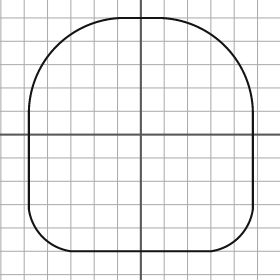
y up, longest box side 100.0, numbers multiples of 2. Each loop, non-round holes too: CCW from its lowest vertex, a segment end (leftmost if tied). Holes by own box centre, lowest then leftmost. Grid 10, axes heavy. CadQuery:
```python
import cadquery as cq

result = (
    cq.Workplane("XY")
    .moveTo(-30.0, -50.0)
    .lineTo(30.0, -50.0)
    .threePointArc((42.0, -44.0), (48.0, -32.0))
    .lineTo(48.0, 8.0)
    .threePointArc((36.0, 38.0), (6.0, 50.0))
    .lineTo(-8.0, 50.0)
    .threePointArc((-36.0, 38.0), (-48.0, 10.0))
    .lineTo(-48.0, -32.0)
    .threePointArc((-42.0, -44.0), (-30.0, -50.0))
    .close()
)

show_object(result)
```